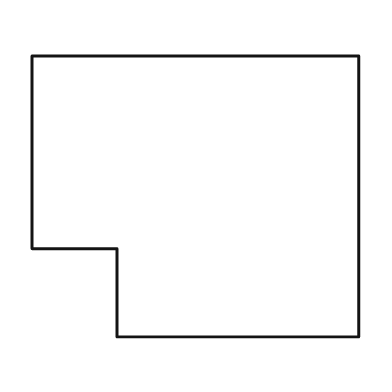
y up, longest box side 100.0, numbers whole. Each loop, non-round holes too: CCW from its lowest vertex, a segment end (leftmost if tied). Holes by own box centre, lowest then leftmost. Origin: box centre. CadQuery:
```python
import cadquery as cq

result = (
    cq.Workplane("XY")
    .moveTo(-24.0, -43.0)
    .lineTo(50.0, -43.0)
    .lineTo(50.0, 43.0)
    .lineTo(-50.0, 43.0)
    .lineTo(-50.0, -16.0)
    .lineTo(-24.0, -16.0)
    .close()
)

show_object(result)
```